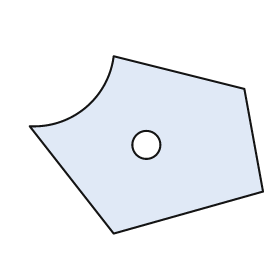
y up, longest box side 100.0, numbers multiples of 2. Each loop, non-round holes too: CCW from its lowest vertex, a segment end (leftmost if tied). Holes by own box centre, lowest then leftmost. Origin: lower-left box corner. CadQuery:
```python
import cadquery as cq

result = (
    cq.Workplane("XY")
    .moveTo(36.0, 0.0)
    .lineTo(100.0, 18.0)
    .lineTo(92.0, 62.0)
    .lineTo(36.0, 76.0)
    .threePointArc((24.0, 54.0), (0.0, 46.0))
    .close()
    .moveTo(50.0, 38.0)
    .circle(6.0)
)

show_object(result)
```